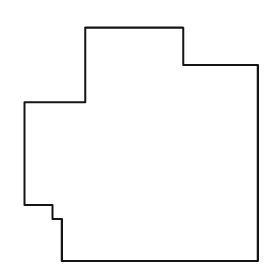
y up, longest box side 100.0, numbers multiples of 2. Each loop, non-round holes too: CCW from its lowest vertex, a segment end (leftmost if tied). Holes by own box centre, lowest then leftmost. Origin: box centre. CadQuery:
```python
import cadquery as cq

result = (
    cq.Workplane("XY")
    .moveTo(-34.0, -50.0)
    .lineTo(50.0, -50.0)
    .lineTo(50.0, 34.0)
    .lineTo(18.0, 34.0)
    .lineTo(18.0, 50.0)
    .lineTo(-24.0, 50.0)
    .lineTo(-24.0, 18.0)
    .lineTo(-50.0, 18.0)
    .lineTo(-50.0, -26.0)
    .lineTo(-38.0, -26.0)
    .lineTo(-38.0, -32.0)
    .lineTo(-34.0, -32.0)
    .close()
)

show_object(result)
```